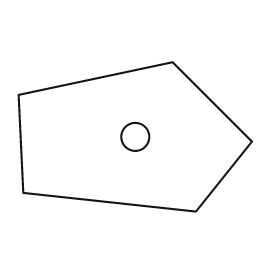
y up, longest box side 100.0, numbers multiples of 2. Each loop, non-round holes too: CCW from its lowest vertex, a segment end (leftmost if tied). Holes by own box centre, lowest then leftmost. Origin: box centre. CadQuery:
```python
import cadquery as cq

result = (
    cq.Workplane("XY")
    .moveTo(26.0, -32.0)
    .lineTo(50.0, -2.0)
    .lineTo(16.0, 32.0)
    .lineTo(-50.0, 18.0)
    .lineTo(-48.0, -24.0)
    .close()
    .moveTo(0.0, 0.0)
    .circle(6.0)
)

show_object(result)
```